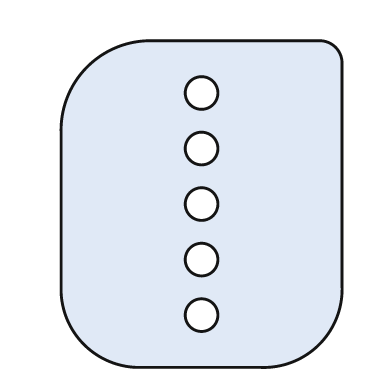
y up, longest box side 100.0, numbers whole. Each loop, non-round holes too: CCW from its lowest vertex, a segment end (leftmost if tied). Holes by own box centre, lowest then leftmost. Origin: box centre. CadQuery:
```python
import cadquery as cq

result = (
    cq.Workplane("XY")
    .moveTo(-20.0, -50.0)
    .lineTo(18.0, -50.0)
    .threePointArc((36.0, -43.0), (43.0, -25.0))
    .lineTo(43.0, 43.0)
    .threePointArc((41.0, 48.0), (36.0, 50.0))
    .lineTo(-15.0, 50.0)
    .threePointArc((-35.0, 42.0), (-43.0, 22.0))
    .lineTo(-43.0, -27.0)
    .threePointArc((-36.0, -43.0), (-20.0, -50.0))
    .close()
    .moveTo(0.0, -34.0)
    .circle(5.0)
    .moveTo(0.0, -17.0)
    .circle(5.0)
    .moveTo(0.0, 0.0)
    .circle(5.0)
    .moveTo(0.0, 17.0)
    .circle(5.0)
    .moveTo(0.0, 34.0)
    .circle(5.0)
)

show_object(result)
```